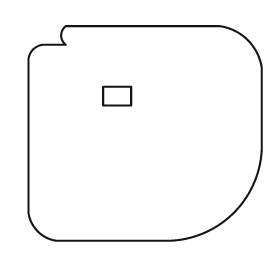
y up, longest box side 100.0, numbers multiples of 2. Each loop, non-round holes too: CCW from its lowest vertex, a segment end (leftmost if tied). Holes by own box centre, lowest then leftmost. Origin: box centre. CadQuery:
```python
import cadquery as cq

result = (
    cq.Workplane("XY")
    .moveTo(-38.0, -46.0)
    .lineTo(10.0, -46.0)
    .threePointArc((38.0, -34.0), (50.0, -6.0))
    .lineTo(50.0, 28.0)
    .threePointArc((44.0, 40.0), (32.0, 46.0))
    .lineTo(-34.0, 46.0)
    .threePointArc((-36.0, 42.0), (-34.0, 38.0))
    .lineTo(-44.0, 38.0)
    .threePointArc((-48.0, 36.0), (-50.0, 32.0))
    .lineTo(-50.0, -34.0)
    .threePointArc((-46.0, -42.0), (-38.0, -46.0))
    .close()
    .moveTo(-18.0, 12.0)
    .lineTo(-6.0, 12.0)
    .lineTo(-6.0, 20.0)
    .lineTo(-18.0, 20.0)
    .close()
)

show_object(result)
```